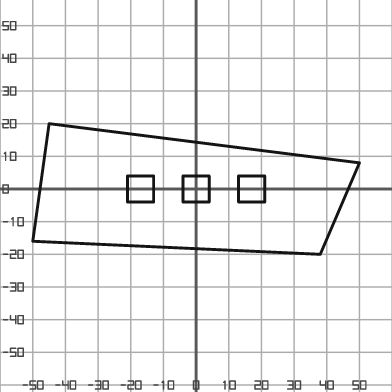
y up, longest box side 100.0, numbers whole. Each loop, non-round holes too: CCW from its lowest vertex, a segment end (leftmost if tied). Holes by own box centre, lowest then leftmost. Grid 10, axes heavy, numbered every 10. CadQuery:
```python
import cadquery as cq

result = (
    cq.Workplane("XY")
    .moveTo(38.0, -20.0)
    .lineTo(50.0, 8.0)
    .lineTo(-45.0, 20.0)
    .lineTo(-50.0, -16.0)
    .close()
    .moveTo(-21.0, -4.0)
    .lineTo(-13.0, -4.0)
    .lineTo(-13.0, 4.0)
    .lineTo(-21.0, 4.0)
    .close()
    .moveTo(-4.0, -4.0)
    .lineTo(4.0, -4.0)
    .lineTo(4.0, 4.0)
    .lineTo(-4.0, 4.0)
    .close()
    .moveTo(13.0, -4.0)
    .lineTo(21.0, -4.0)
    .lineTo(21.0, 4.0)
    .lineTo(13.0, 4.0)
    .close()
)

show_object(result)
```